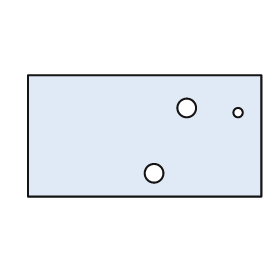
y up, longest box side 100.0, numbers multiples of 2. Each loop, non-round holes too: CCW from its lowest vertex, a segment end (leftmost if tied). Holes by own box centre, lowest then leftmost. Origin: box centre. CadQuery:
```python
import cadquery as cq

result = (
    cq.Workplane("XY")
    .moveTo(-50.0, -26.0)
    .lineTo(50.0, -26.0)
    .lineTo(50.0, 26.0)
    .lineTo(-50.0, 26.0)
    .close()
    .moveTo(4.0, -16.0)
    .circle(4.0)
    .moveTo(40.0, 10.0)
    .circle(2.0)
    .moveTo(18.0, 12.0)
    .circle(4.0)
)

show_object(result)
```